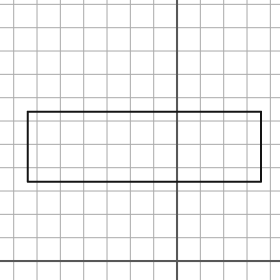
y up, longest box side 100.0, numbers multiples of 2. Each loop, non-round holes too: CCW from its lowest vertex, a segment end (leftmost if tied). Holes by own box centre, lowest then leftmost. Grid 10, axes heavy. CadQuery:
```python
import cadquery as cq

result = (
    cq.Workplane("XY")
    .moveTo(-64.0, 34.0)
    .lineTo(36.0, 34.0)
    .lineTo(36.0, 64.0)
    .lineTo(-64.0, 64.0)
    .close()
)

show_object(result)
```